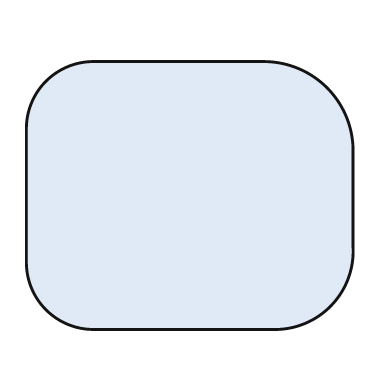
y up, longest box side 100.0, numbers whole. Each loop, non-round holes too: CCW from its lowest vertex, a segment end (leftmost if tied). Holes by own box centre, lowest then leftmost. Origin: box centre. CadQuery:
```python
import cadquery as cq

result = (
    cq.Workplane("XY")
    .moveTo(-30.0, -41.0)
    .lineTo(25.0, -41.0)
    .threePointArc((43.0, -34.0), (50.0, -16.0))
    .lineTo(50.0, 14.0)
    .threePointArc((42.0, 33.0), (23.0, 41.0))
    .lineTo(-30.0, 41.0)
    .threePointArc((-44.0, 35.0), (-50.0, 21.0))
    .lineTo(-50.0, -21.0)
    .threePointArc((-44.0, -35.0), (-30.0, -41.0))
    .close()
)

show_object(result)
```